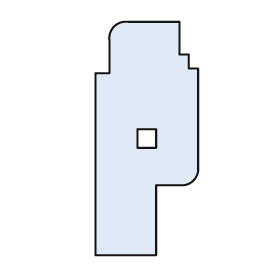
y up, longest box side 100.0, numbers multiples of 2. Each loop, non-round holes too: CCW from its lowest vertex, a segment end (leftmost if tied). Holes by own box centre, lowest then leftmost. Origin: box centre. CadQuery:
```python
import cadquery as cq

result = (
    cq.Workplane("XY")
    .moveTo(-22.0, -50.0)
    .lineTo(4.0, -50.0)
    .lineTo(4.0, -20.0)
    .lineTo(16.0, -20.0)
    .threePointArc((20.0, -18.0), (22.0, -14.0))
    .lineTo(22.0, 30.0)
    .lineTo(18.0, 30.0)
    .lineTo(18.0, 36.0)
    .lineTo(14.0, 36.0)
    .lineTo(14.0, 50.0)
    .lineTo(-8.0, 50.0)
    .threePointArc((-14.0, 48.0), (-16.0, 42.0))
    .lineTo(-16.0, 28.0)
    .lineTo(-22.0, 28.0)
    .close()
    .moveTo(-4.0, -4.0)
    .lineTo(4.0, -4.0)
    .lineTo(4.0, 4.0)
    .lineTo(-4.0, 4.0)
    .close()
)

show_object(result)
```